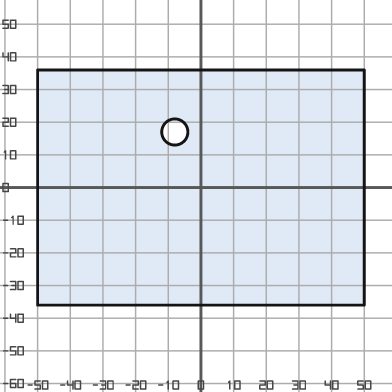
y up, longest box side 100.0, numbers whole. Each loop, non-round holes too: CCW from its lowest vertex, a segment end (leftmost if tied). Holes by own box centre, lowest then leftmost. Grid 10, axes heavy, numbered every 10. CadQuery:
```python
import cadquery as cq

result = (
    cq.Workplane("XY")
    .moveTo(-50.0, -36.0)
    .lineTo(50.0, -36.0)
    .lineTo(50.0, 36.0)
    .lineTo(-50.0, 36.0)
    .close()
    .moveTo(-8.0, 17.0)
    .circle(4.0)
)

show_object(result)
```